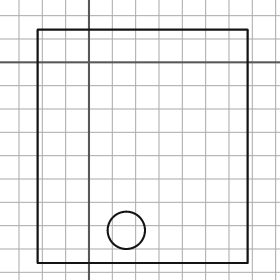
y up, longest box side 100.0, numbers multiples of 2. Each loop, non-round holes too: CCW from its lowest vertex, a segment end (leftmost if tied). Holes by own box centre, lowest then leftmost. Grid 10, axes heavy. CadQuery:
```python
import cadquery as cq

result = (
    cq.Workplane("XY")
    .moveTo(-22.0, -86.0)
    .lineTo(68.0, -86.0)
    .lineTo(68.0, 14.0)
    .lineTo(-22.0, 14.0)
    .close()
    .moveTo(16.0, -72.0)
    .circle(8.0)
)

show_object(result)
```